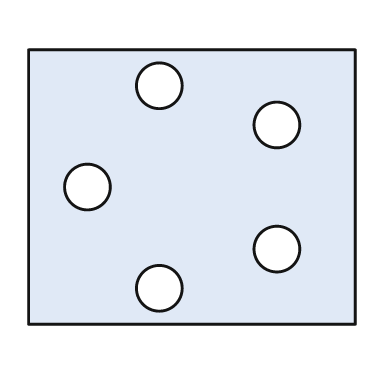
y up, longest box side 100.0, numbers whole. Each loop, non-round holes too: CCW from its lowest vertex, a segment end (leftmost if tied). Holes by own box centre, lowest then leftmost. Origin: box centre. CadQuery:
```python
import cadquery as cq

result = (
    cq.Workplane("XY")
    .moveTo(-50.0, -42.0)
    .lineTo(50.0, -42.0)
    .lineTo(50.0, 42.0)
    .lineTo(-50.0, 42.0)
    .close()
    .moveTo(-10.0, -31.0)
    .circle(7.0)
    .moveTo(26.0, -19.0)
    .circle(7.0)
    .moveTo(-32.0, 0.0)
    .circle(7.0)
    .moveTo(26.0, 19.0)
    .circle(7.0)
    .moveTo(-10.0, 31.0)
    .circle(7.0)
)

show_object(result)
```